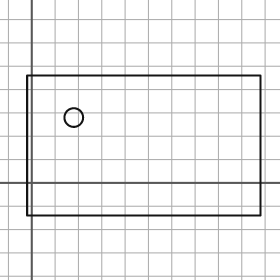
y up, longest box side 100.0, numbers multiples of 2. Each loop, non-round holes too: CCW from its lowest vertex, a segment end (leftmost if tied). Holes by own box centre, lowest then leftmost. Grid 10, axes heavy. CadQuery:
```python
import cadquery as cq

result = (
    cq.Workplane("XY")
    .moveTo(-2.0, -14.0)
    .lineTo(98.0, -14.0)
    .lineTo(98.0, 46.0)
    .lineTo(-2.0, 46.0)
    .close()
    .moveTo(18.0, 28.0)
    .circle(4.0)
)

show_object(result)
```